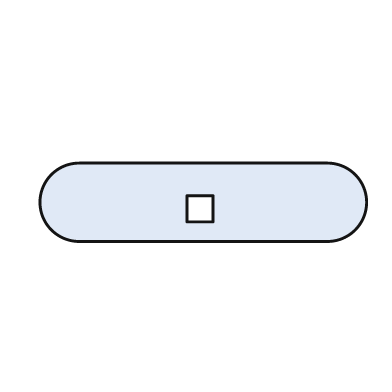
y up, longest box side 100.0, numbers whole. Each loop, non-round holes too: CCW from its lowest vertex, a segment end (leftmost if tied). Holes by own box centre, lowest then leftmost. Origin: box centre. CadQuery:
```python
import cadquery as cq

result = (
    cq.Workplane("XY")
    .moveTo(-38.0, -12.0)
    .lineTo(38.0, -12.0)
    .threePointArc((50.0, 0.0), (38.0, 12.0))
    .lineTo(-38.0, 12.0)
    .threePointArc((-50.0, 0.0), (-38.0, -12.0))
    .close()
    .moveTo(-5.0, -6.0)
    .lineTo(3.0, -6.0)
    .lineTo(3.0, 2.0)
    .lineTo(-5.0, 2.0)
    .close()
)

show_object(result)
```